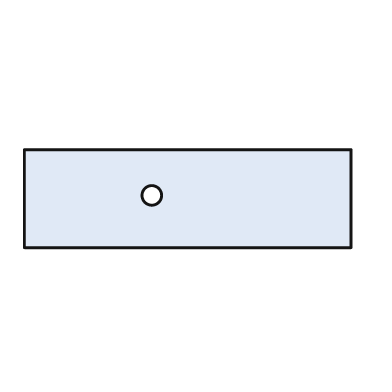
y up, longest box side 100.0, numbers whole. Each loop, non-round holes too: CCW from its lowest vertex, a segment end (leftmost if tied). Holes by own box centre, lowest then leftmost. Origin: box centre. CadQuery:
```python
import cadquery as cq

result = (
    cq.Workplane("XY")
    .moveTo(-50.0, -15.0)
    .lineTo(50.0, -15.0)
    .lineTo(50.0, 15.0)
    .lineTo(-50.0, 15.0)
    .close()
    .moveTo(-11.0, 1.0)
    .circle(3.0)
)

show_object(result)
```